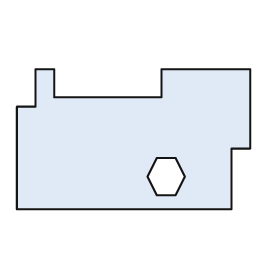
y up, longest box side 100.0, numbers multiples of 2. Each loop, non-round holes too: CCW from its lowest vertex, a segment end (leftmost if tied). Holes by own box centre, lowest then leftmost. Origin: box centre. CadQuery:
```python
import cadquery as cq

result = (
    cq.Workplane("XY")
    .moveTo(-50.0, -30.0)
    .lineTo(42.0, -30.0)
    .lineTo(42.0, -4.0)
    .lineTo(50.0, -4.0)
    .lineTo(50.0, 30.0)
    .lineTo(12.0, 30.0)
    .lineTo(12.0, 18.0)
    .lineTo(-34.0, 18.0)
    .lineTo(-34.0, 30.0)
    .lineTo(-42.0, 30.0)
    .lineTo(-42.0, 14.0)
    .lineTo(-50.0, 14.0)
    .close()
    .moveTo(10.0, -24.0)
    .lineTo(18.0, -24.0)
    .lineTo(22.0, -16.0)
    .lineTo(18.0, -8.0)
    .lineTo(10.0, -8.0)
    .lineTo(6.0, -16.0)
    .close()
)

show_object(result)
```